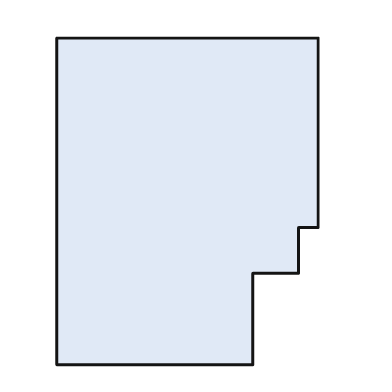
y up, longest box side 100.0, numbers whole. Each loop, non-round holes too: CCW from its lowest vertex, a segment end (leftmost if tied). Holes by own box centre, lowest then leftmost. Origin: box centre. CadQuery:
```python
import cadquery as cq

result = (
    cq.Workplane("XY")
    .moveTo(-40.0, -50.0)
    .lineTo(20.0, -50.0)
    .lineTo(20.0, -22.0)
    .lineTo(34.0, -22.0)
    .lineTo(34.0, -8.0)
    .lineTo(40.0, -8.0)
    .lineTo(40.0, 50.0)
    .lineTo(-40.0, 50.0)
    .close()
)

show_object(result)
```